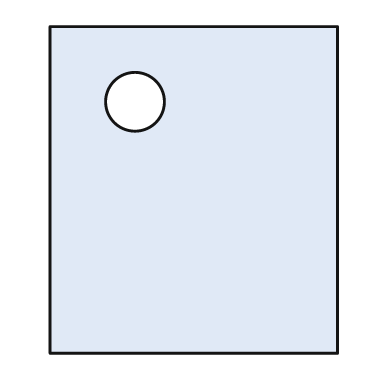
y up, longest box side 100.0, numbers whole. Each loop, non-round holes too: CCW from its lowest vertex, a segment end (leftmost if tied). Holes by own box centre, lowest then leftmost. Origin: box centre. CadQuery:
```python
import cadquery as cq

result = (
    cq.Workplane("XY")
    .moveTo(-44.0, -50.0)
    .lineTo(44.0, -50.0)
    .lineTo(44.0, 50.0)
    .lineTo(-44.0, 50.0)
    .close()
    .moveTo(-18.0, 27.0)
    .circle(9.0)
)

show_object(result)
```